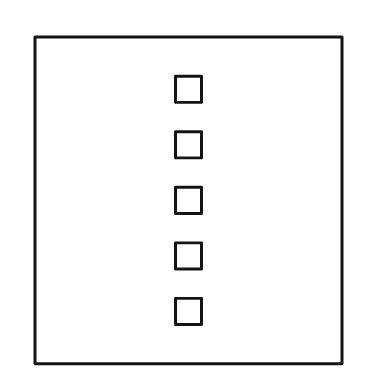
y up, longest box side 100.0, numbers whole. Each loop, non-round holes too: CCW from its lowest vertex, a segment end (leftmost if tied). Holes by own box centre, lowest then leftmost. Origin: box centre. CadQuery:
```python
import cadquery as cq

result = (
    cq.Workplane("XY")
    .moveTo(-47.0, -50.0)
    .lineTo(47.0, -50.0)
    .lineTo(47.0, 50.0)
    .lineTo(-47.0, 50.0)
    .close()
    .moveTo(-4.0, -38.0)
    .lineTo(4.0, -38.0)
    .lineTo(4.0, -30.0)
    .lineTo(-4.0, -30.0)
    .close()
    .moveTo(-4.0, -21.0)
    .lineTo(4.0, -21.0)
    .lineTo(4.0, -13.0)
    .lineTo(-4.0, -13.0)
    .close()
    .moveTo(-4.0, -4.0)
    .lineTo(4.0, -4.0)
    .lineTo(4.0, 4.0)
    .lineTo(-4.0, 4.0)
    .close()
    .moveTo(-4.0, 13.0)
    .lineTo(4.0, 13.0)
    .lineTo(4.0, 21.0)
    .lineTo(-4.0, 21.0)
    .close()
    .moveTo(-4.0, 30.0)
    .lineTo(4.0, 30.0)
    .lineTo(4.0, 38.0)
    .lineTo(-4.0, 38.0)
    .close()
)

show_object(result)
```